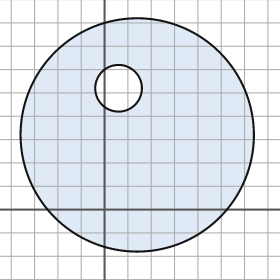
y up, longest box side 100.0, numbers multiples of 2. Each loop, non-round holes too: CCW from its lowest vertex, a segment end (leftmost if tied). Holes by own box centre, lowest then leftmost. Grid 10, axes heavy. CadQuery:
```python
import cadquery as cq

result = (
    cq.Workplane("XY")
    .moveTo(14.0, 32.0)
    .circle(50.0)
    .moveTo(6.0, 52.0)
    .circle(10.0)
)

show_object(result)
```